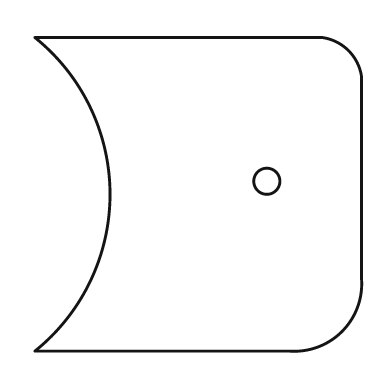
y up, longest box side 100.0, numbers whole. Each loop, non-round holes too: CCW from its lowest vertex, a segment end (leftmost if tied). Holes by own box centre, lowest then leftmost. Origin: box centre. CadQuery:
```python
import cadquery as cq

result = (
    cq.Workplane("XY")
    .moveTo(-50.0, -48.0)
    .lineTo(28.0, -48.0)
    .threePointArc((44.0, -42.0), (50.0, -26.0))
    .lineTo(50.0, 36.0)
    .threePointArc((46.0, 44.0), (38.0, 48.0))
    .lineTo(-50.0, 48.0)
    .threePointArc((-27.0, 0.0), (-50.0, -48.0))
    .close()
    .moveTo(21.0, 4.0)
    .circle(4.0)
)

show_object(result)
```